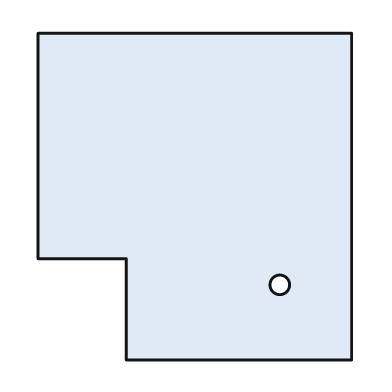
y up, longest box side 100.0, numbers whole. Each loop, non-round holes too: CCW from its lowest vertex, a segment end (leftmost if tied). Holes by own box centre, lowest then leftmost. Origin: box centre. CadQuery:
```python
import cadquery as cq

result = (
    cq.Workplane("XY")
    .moveTo(-21.0, -50.0)
    .lineTo(48.0, -50.0)
    .lineTo(48.0, 50.0)
    .lineTo(-48.0, 50.0)
    .lineTo(-48.0, -19.0)
    .lineTo(-21.0, -19.0)
    .close()
    .moveTo(26.0, -27.0)
    .circle(3.0)
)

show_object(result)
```